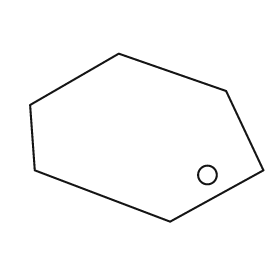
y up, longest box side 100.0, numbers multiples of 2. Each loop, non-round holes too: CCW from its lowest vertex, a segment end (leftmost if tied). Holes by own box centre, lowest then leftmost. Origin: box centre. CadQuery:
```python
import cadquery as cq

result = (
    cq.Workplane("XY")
    .moveTo(10.0, -36.0)
    .lineTo(50.0, -14.0)
    .lineTo(34.0, 20.0)
    .lineTo(-12.0, 36.0)
    .lineTo(-50.0, 14.0)
    .lineTo(-48.0, -14.0)
    .close()
    .moveTo(26.0, -16.0)
    .circle(4.0)
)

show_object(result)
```